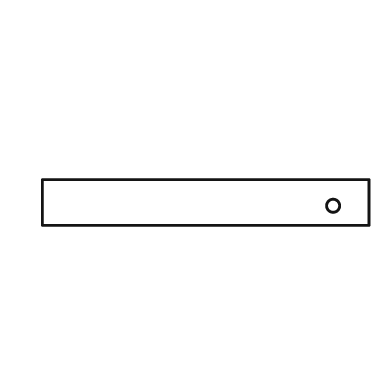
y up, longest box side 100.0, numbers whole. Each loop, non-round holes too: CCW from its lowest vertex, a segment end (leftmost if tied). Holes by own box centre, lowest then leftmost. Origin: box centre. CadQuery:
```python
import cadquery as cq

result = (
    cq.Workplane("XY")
    .moveTo(-50.0, -7.0)
    .lineTo(50.0, -7.0)
    .lineTo(50.0, 7.0)
    .lineTo(-50.0, 7.0)
    .close()
    .moveTo(39.0, -1.0)
    .circle(2.0)
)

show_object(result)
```